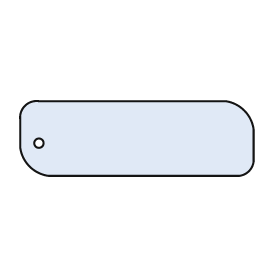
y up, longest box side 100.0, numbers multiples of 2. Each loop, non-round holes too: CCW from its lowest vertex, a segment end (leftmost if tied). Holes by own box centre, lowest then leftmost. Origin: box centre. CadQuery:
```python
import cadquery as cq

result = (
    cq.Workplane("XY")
    .moveTo(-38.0, -16.0)
    .lineTo(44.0, -16.0)
    .threePointArc((48.0, -14.0), (50.0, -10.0))
    .lineTo(50.0, 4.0)
    .threePointArc((46.0, 12.0), (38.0, 16.0))
    .lineTo(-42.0, 16.0)
    .threePointArc((-48.0, 14.0), (-50.0, 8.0))
    .lineTo(-50.0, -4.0)
    .threePointArc((-46.0, -12.0), (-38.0, -16.0))
    .close()
    .moveTo(-42.0, -2.0)
    .circle(2.0)
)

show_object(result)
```